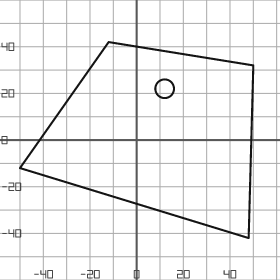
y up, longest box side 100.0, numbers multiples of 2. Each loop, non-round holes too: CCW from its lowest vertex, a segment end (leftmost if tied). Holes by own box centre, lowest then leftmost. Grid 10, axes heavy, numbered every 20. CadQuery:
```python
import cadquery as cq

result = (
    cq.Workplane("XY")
    .moveTo(48.0, -42.0)
    .lineTo(50.0, 32.0)
    .lineTo(-12.0, 42.0)
    .lineTo(-50.0, -12.0)
    .close()
    .moveTo(12.0, 22.0)
    .circle(4.0)
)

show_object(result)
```